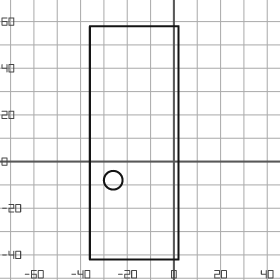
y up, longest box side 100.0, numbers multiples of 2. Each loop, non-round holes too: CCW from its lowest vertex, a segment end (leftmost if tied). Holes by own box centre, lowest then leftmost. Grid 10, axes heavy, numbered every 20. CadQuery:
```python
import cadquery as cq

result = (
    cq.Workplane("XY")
    .moveTo(-36.0, -42.0)
    .lineTo(2.0, -42.0)
    .lineTo(2.0, 58.0)
    .lineTo(-36.0, 58.0)
    .close()
    .moveTo(-26.0, -8.0)
    .circle(4.0)
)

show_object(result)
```